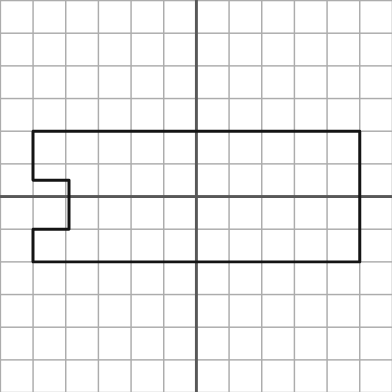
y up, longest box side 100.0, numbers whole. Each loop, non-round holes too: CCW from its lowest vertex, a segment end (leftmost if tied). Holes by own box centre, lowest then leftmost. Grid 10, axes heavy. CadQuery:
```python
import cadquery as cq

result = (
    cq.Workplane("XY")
    .moveTo(-50.0, -20.0)
    .lineTo(50.0, -20.0)
    .lineTo(50.0, 20.0)
    .lineTo(-50.0, 20.0)
    .lineTo(-50.0, 5.0)
    .lineTo(-39.0, 5.0)
    .lineTo(-39.0, -10.0)
    .lineTo(-50.0, -10.0)
    .close()
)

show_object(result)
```